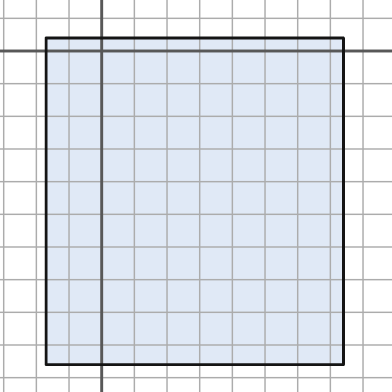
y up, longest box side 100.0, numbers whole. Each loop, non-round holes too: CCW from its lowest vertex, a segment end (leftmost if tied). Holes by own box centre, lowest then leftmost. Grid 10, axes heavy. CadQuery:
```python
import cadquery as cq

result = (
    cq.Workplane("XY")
    .moveTo(-17.0, -96.0)
    .lineTo(74.0, -96.0)
    .lineTo(74.0, 4.0)
    .lineTo(-17.0, 4.0)
    .close()
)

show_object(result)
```